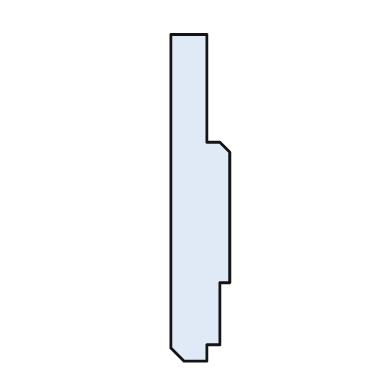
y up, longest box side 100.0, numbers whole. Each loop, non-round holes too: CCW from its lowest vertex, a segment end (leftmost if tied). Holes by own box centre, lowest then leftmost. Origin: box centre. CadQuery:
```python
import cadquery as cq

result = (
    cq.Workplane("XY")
    .moveTo(-5.0, -50.0)
    .lineTo(2.0, -50.0)
    .lineTo(2.0, -45.0)
    .lineTo(6.0, -45.0)
    .lineTo(6.0, -26.0)
    .lineTo(9.0, -26.0)
    .lineTo(9.0, 14.0)
    .lineTo(6.0, 17.0)
    .lineTo(2.0, 17.0)
    .lineTo(2.0, 50.0)
    .lineTo(-9.0, 50.0)
    .lineTo(-9.0, -46.0)
    .close()
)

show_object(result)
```